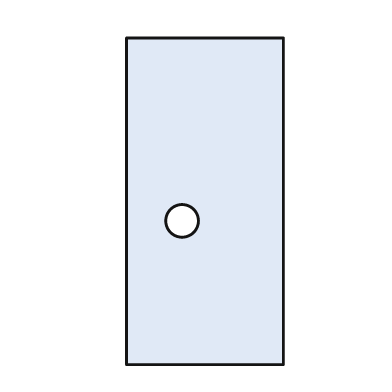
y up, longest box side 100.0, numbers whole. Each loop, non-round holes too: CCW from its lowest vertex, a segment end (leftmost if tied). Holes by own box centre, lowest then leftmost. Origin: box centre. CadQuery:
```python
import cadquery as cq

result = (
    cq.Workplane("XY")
    .moveTo(-24.0, -50.0)
    .lineTo(24.0, -50.0)
    .lineTo(24.0, 50.0)
    .lineTo(-24.0, 50.0)
    .close()
    .moveTo(-7.0, -6.0)
    .circle(5.0)
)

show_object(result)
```